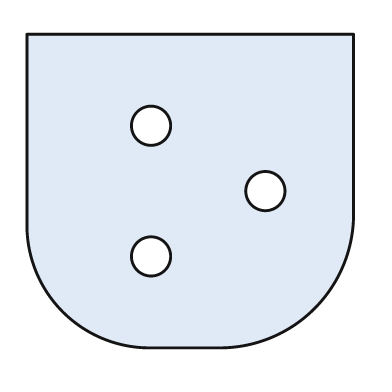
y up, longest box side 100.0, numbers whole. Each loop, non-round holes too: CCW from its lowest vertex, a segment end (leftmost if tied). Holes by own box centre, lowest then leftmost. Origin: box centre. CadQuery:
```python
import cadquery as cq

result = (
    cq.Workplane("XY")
    .moveTo(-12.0, -48.0)
    .lineTo(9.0, -48.0)
    .threePointArc((38.0, -36.0), (50.0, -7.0))
    .lineTo(50.0, 48.0)
    .lineTo(-50.0, 48.0)
    .lineTo(-50.0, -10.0)
    .threePointArc((-39.0, -37.0), (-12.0, -48.0))
    .close()
    .moveTo(-12.0, -20.0)
    .circle(6.0)
    .moveTo(23.0, 0.0)
    .circle(6.0)
    .moveTo(-12.0, 20.0)
    .circle(6.0)
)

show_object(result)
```